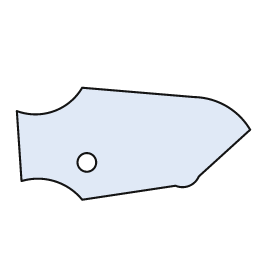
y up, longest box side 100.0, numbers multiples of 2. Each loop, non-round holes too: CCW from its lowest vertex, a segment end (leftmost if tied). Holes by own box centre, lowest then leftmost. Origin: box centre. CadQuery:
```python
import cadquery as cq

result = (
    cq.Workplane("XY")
    .moveTo(-22.0, -24.0)
    .lineTo(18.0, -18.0)
    .threePointArc((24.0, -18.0), (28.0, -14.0))
    .lineTo(50.0, 6.0)
    .threePointArc((40.0, 16.0), (26.0, 20.0))
    .lineTo(-22.0, 24.0)
    .threePointArc((-34.0, 14.0), (-50.0, 14.0))
    .lineTo(-48.0, -16.0)
    .threePointArc((-34.0, -16.0), (-22.0, -24.0))
    .close()
    .moveTo(-20.0, -8.0)
    .circle(4.0)
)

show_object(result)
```